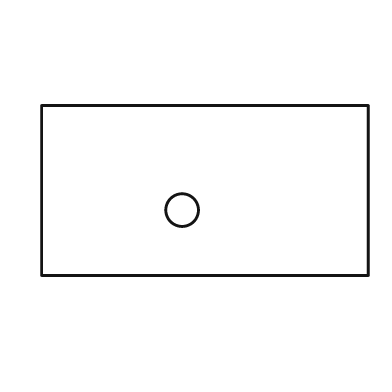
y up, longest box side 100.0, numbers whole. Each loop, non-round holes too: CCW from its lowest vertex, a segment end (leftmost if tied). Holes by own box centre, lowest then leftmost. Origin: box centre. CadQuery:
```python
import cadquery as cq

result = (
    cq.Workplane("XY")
    .moveTo(-50.0, -26.0)
    .lineTo(50.0, -26.0)
    .lineTo(50.0, 26.0)
    .lineTo(-50.0, 26.0)
    .close()
    .moveTo(-7.0, -6.0)
    .circle(5.0)
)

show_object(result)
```